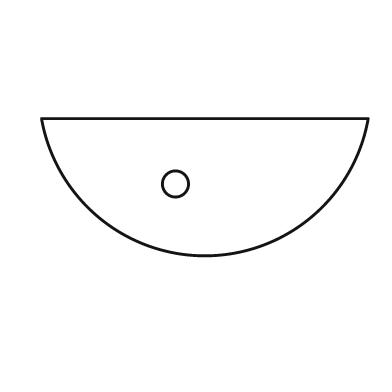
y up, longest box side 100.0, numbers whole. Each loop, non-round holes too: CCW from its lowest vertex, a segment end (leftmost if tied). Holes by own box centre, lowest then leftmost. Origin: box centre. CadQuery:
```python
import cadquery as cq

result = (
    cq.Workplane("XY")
    .moveTo(-50.0, 21.0)
    .threePointArc((0.0, -21.0), (50.0, 21.0))
    .close()
    .moveTo(-9.0, 1.0)
    .circle(4.0)
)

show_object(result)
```